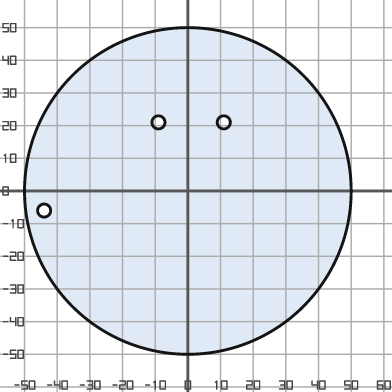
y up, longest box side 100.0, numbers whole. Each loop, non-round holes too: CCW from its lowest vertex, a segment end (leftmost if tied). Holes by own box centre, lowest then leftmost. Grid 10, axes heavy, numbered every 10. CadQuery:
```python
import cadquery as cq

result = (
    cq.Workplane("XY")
    .moveTo(0.0, 0.0)
    .circle(50.0)
    .moveTo(-44.0, -6.0)
    .circle(2.0)
    .moveTo(-9.0, 21.0)
    .circle(2.0)
    .moveTo(11.0, 21.0)
    .circle(2.0)
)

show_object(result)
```